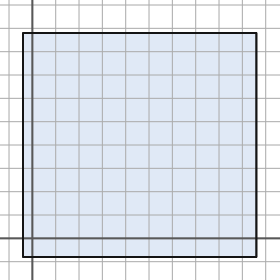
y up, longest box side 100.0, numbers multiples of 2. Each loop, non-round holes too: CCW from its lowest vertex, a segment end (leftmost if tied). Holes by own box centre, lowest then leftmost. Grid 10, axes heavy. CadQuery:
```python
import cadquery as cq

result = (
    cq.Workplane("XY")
    .moveTo(-4.0, -8.0)
    .lineTo(96.0, -8.0)
    .lineTo(96.0, 88.0)
    .lineTo(-4.0, 88.0)
    .close()
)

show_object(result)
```